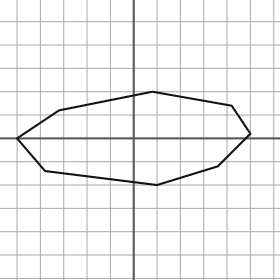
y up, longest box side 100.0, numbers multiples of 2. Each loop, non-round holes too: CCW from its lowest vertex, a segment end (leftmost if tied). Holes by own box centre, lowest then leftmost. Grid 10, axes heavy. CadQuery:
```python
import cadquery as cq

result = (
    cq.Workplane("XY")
    .moveTo(10.0, -20.0)
    .lineTo(36.0, -12.0)
    .lineTo(50.0, 2.0)
    .lineTo(42.0, 14.0)
    .lineTo(8.0, 20.0)
    .lineTo(-32.0, 12.0)
    .lineTo(-50.0, 0.0)
    .lineTo(-38.0, -14.0)
    .close()
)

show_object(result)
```